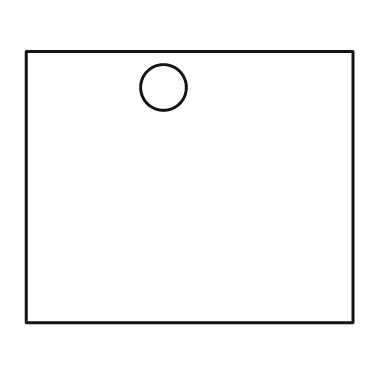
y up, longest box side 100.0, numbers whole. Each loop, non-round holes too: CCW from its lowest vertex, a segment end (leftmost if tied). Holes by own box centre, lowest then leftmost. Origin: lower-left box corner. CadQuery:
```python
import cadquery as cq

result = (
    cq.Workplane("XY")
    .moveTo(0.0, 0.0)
    .lineTo(100.0, 0.0)
    .lineTo(100.0, 83.0)
    .lineTo(0.0, 83.0)
    .close()
    .moveTo(42.0, 72.0)
    .circle(7.0)
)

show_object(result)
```